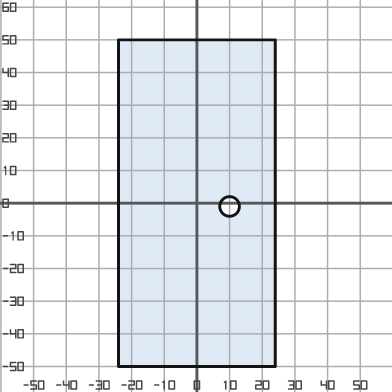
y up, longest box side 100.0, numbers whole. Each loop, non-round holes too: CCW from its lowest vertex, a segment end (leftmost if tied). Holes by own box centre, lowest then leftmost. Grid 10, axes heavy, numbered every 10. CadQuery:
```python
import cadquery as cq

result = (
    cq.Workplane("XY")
    .moveTo(-24.0, -50.0)
    .lineTo(24.0, -50.0)
    .lineTo(24.0, 50.0)
    .lineTo(-24.0, 50.0)
    .close()
    .moveTo(10.0, -1.0)
    .circle(3.0)
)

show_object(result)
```